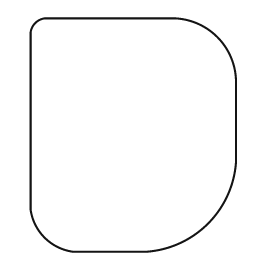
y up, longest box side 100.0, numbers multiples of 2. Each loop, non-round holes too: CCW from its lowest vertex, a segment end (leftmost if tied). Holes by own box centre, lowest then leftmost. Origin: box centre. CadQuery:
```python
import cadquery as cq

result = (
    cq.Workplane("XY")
    .moveTo(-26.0, -50.0)
    .lineTo(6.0, -50.0)
    .threePointArc((32.0, -38.0), (44.0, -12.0))
    .lineTo(44.0, 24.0)
    .threePointArc((36.0, 42.0), (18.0, 50.0))
    .lineTo(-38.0, 50.0)
    .threePointArc((-42.0, 48.0), (-44.0, 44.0))
    .lineTo(-44.0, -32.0)
    .threePointArc((-38.0, -44.0), (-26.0, -50.0))
    .close()
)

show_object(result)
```